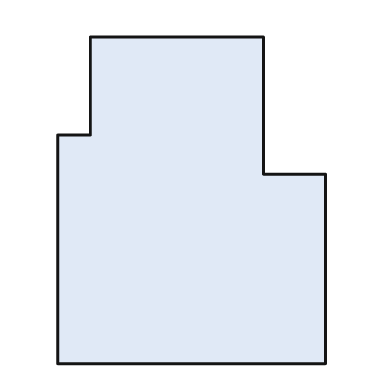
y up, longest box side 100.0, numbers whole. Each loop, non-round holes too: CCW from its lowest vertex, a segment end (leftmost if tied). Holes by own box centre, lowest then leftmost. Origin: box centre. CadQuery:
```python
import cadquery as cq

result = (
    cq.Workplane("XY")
    .moveTo(-41.0, -50.0)
    .lineTo(41.0, -50.0)
    .lineTo(41.0, 8.0)
    .lineTo(22.0, 8.0)
    .lineTo(22.0, 50.0)
    .lineTo(-31.0, 50.0)
    .lineTo(-31.0, 20.0)
    .lineTo(-41.0, 20.0)
    .close()
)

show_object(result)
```